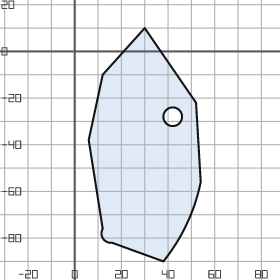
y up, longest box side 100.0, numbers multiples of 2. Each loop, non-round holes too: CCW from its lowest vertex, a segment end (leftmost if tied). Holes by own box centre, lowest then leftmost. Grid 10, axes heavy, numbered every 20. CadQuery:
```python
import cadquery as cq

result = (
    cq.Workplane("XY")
    .moveTo(38.0, -90.0)
    .threePointArc((48.0, -74.0), (54.0, -56.0))
    .lineTo(52.0, -22.0)
    .lineTo(30.0, 10.0)
    .lineTo(12.0, -10.0)
    .lineTo(6.0, -38.0)
    .lineTo(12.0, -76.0)
    .threePointArc((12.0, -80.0), (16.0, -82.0))
    .close()
    .moveTo(42.0, -28.0)
    .circle(4.0)
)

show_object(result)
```